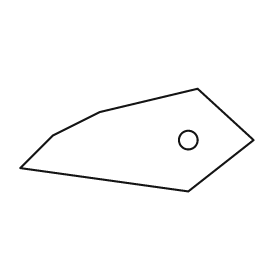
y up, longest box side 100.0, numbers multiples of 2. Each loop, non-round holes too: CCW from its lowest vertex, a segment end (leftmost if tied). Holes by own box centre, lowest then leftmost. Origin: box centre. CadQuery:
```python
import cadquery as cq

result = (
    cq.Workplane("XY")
    .moveTo(22.0, -22.0)
    .lineTo(50.0, 0.0)
    .lineTo(26.0, 22.0)
    .lineTo(-16.0, 12.0)
    .lineTo(-36.0, 2.0)
    .lineTo(-50.0, -12.0)
    .close()
    .moveTo(22.0, 0.0)
    .circle(4.0)
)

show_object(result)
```